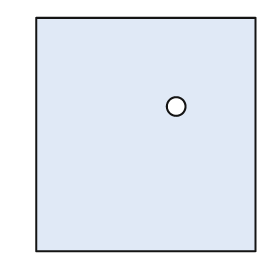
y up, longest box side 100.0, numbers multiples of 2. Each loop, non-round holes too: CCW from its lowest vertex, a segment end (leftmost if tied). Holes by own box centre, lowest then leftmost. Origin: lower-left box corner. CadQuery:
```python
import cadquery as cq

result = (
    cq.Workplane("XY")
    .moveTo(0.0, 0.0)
    .lineTo(94.0, 0.0)
    .lineTo(94.0, 100.0)
    .lineTo(0.0, 100.0)
    .close()
    .moveTo(60.0, 62.0)
    .circle(4.0)
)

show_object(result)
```